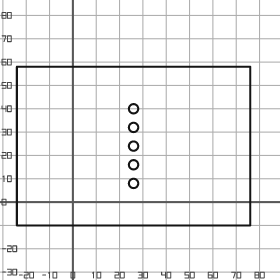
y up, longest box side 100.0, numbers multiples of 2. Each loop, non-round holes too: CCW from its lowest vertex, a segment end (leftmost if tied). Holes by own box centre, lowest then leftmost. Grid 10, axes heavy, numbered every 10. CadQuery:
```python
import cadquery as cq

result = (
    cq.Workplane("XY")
    .moveTo(-24.0, -10.0)
    .lineTo(76.0, -10.0)
    .lineTo(76.0, 58.0)
    .lineTo(-24.0, 58.0)
    .close()
    .moveTo(26.0, 8.0)
    .circle(2.0)
    .moveTo(26.0, 16.0)
    .circle(2.0)
    .moveTo(26.0, 24.0)
    .circle(2.0)
    .moveTo(26.0, 32.0)
    .circle(2.0)
    .moveTo(26.0, 40.0)
    .circle(2.0)
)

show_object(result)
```